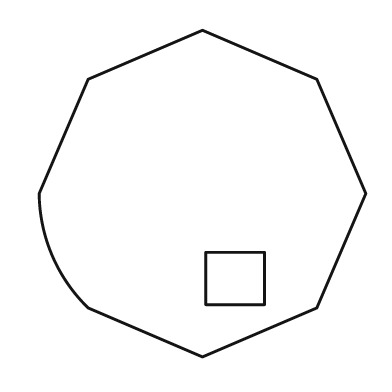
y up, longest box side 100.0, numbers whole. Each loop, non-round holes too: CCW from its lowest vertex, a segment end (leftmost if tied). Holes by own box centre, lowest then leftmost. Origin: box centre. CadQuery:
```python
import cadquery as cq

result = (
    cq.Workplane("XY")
    .moveTo(0.0, -50.0)
    .lineTo(35.0, -35.0)
    .lineTo(50.0, 0.0)
    .lineTo(35.0, 35.0)
    .lineTo(0.0, 50.0)
    .lineTo(-35.0, 35.0)
    .lineTo(-50.0, 0.0)
    .threePointArc((-46.0, -19.0), (-35.0, -35.0))
    .close()
    .moveTo(1.0, -34.0)
    .lineTo(19.0, -34.0)
    .lineTo(19.0, -18.0)
    .lineTo(1.0, -18.0)
    .close()
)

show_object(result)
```